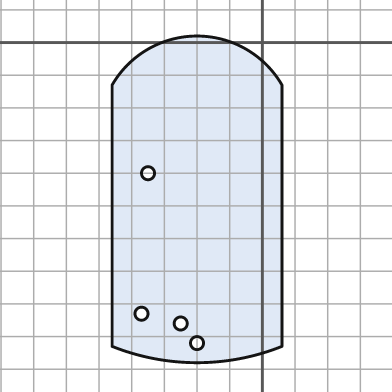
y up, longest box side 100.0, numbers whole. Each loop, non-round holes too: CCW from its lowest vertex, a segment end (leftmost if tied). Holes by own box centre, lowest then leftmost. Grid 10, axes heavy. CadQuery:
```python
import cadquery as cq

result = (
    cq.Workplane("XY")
    .moveTo(-46.0, -93.0)
    .threePointArc((-20.0, -98.0), (6.0, -93.0))
    .lineTo(6.0, -13.0)
    .threePointArc((-20.0, 2.0), (-46.0, -13.0))
    .close()
    .moveTo(-20.0, -92.0)
    .circle(2.0)
    .moveTo(-25.0, -86.0)
    .circle(2.0)
    .moveTo(-37.0, -83.0)
    .circle(2.0)
    .moveTo(-35.0, -40.0)
    .circle(2.0)
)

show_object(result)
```